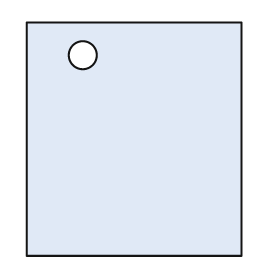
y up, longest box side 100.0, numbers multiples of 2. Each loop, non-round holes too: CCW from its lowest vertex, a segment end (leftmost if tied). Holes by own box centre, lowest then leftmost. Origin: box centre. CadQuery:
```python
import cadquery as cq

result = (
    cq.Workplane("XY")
    .moveTo(-46.0, -50.0)
    .lineTo(46.0, -50.0)
    .lineTo(46.0, 50.0)
    .lineTo(-46.0, 50.0)
    .close()
    .moveTo(-22.0, 36.0)
    .circle(6.0)
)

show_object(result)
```